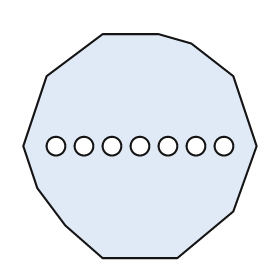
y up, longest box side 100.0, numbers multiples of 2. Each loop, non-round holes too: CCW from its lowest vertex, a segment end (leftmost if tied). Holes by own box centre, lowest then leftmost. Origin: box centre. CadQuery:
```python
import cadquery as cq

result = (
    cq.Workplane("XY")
    .moveTo(-16.0, -48.0)
    .lineTo(16.0, -48.0)
    .lineTo(40.0, -28.0)
    .lineTo(50.0, 0.0)
    .lineTo(40.0, 30.0)
    .lineTo(22.0, 44.0)
    .lineTo(8.0, 48.0)
    .lineTo(-16.0, 48.0)
    .lineTo(-40.0, 30.0)
    .lineTo(-50.0, 0.0)
    .lineTo(-44.0, -18.0)
    .lineTo(-32.0, -34.0)
    .close()
    .moveTo(-36.0, 0.0)
    .circle(4.0)
    .moveTo(-24.0, 0.0)
    .circle(4.0)
    .moveTo(-12.0, 0.0)
    .circle(4.0)
    .moveTo(0.0, 0.0)
    .circle(4.0)
    .moveTo(12.0, 0.0)
    .circle(4.0)
    .moveTo(24.0, 0.0)
    .circle(4.0)
    .moveTo(36.0, 0.0)
    .circle(4.0)
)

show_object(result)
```